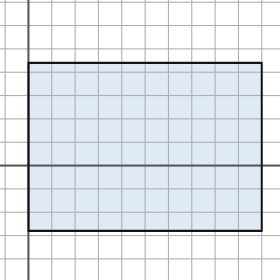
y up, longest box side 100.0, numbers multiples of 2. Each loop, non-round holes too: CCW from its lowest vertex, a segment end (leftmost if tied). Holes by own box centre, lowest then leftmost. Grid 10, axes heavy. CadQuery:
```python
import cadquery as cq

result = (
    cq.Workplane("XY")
    .moveTo(0.0, -28.0)
    .lineTo(100.0, -28.0)
    .lineTo(100.0, 44.0)
    .lineTo(0.0, 44.0)
    .close()
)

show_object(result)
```